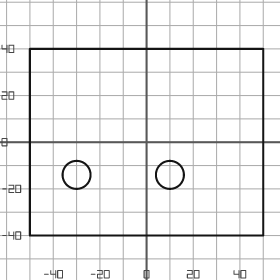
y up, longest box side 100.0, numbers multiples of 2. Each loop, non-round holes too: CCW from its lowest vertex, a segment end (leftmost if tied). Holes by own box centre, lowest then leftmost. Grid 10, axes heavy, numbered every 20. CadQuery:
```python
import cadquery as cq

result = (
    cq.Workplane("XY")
    .moveTo(-50.0, -40.0)
    .lineTo(50.0, -40.0)
    .lineTo(50.0, 40.0)
    .lineTo(-50.0, 40.0)
    .close()
    .moveTo(-30.0, -14.0)
    .circle(6.0)
    .moveTo(10.0, -14.0)
    .circle(6.0)
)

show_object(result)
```